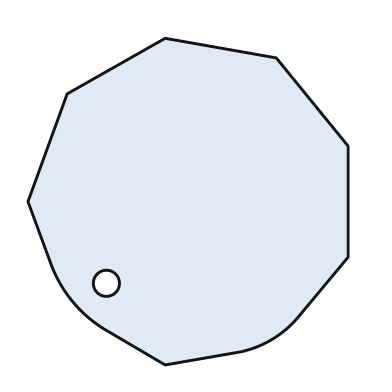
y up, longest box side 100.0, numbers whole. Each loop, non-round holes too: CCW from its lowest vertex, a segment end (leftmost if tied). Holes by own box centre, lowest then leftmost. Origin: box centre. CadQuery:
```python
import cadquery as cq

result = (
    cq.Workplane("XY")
    .moveTo(-7.0, -50.0)
    .lineTo(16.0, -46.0)
    .threePointArc((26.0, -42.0), (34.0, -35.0))
    .lineTo(49.0, -17.0)
    .lineTo(49.0, 17.0)
    .lineTo(27.0, 44.0)
    .lineTo(-7.0, 50.0)
    .lineTo(-37.0, 33.0)
    .lineTo(-49.0, 0.0)
    .lineTo(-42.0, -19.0)
    .threePointArc((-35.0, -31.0), (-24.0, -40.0))
    .close()
    .moveTo(-25.0, -25.0)
    .circle(4.0)
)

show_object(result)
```